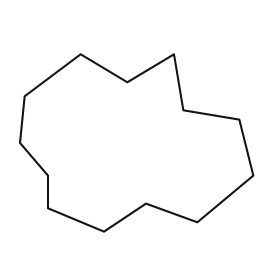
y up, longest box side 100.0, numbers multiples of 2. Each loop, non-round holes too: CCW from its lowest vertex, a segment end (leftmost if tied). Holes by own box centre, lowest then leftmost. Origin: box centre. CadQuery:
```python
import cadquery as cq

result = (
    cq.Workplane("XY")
    .moveTo(-14.0, -38.0)
    .lineTo(4.0, -26.0)
    .lineTo(26.0, -34.0)
    .lineTo(50.0, -14.0)
    .lineTo(44.0, 10.0)
    .lineTo(20.0, 14.0)
    .lineTo(16.0, 38.0)
    .lineTo(-4.0, 26.0)
    .lineTo(-24.0, 38.0)
    .lineTo(-48.0, 20.0)
    .lineTo(-50.0, 0.0)
    .lineTo(-38.0, -14.0)
    .lineTo(-38.0, -28.0)
    .close()
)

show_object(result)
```